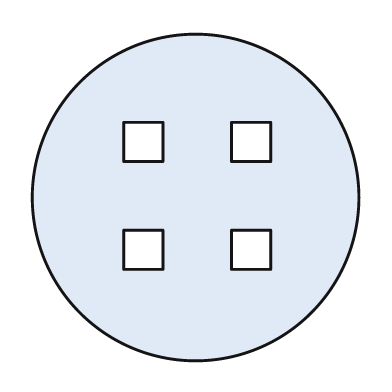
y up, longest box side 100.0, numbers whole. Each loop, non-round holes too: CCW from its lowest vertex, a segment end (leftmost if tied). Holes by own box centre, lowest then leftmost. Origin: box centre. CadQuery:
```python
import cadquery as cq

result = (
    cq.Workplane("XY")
    .moveTo(0.0, 0.0)
    .circle(50.0)
    .moveTo(-22.0, -22.0)
    .lineTo(-10.0, -22.0)
    .lineTo(-10.0, -10.0)
    .lineTo(-22.0, -10.0)
    .close()
    .moveTo(11.0, -22.0)
    .lineTo(23.0, -22.0)
    .lineTo(23.0, -10.0)
    .lineTo(11.0, -10.0)
    .close()
    .moveTo(-22.0, 11.0)
    .lineTo(-10.0, 11.0)
    .lineTo(-10.0, 23.0)
    .lineTo(-22.0, 23.0)
    .close()
    .moveTo(11.0, 11.0)
    .lineTo(23.0, 11.0)
    .lineTo(23.0, 23.0)
    .lineTo(11.0, 23.0)
    .close()
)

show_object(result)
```